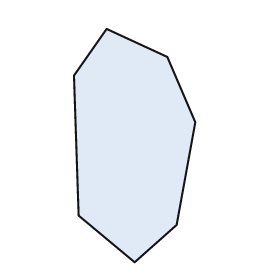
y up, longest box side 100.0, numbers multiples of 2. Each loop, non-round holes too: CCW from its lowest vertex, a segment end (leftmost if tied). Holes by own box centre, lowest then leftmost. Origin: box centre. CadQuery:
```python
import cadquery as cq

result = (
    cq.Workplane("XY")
    .moveTo(0.0, -50.0)
    .lineTo(18.0, -34.0)
    .lineTo(26.0, 10.0)
    .lineTo(14.0, 38.0)
    .lineTo(-12.0, 50.0)
    .lineTo(-26.0, 30.0)
    .lineTo(-24.0, -30.0)
    .close()
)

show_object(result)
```